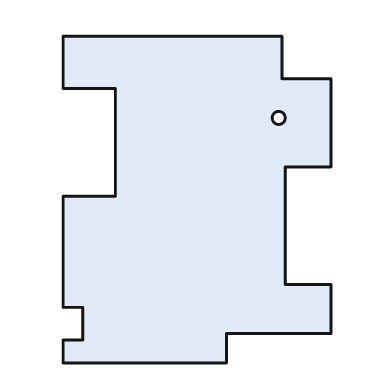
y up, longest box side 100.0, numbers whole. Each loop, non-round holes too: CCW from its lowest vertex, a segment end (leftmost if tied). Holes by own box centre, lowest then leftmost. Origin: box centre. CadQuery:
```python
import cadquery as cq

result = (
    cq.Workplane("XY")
    .moveTo(-41.0, -50.0)
    .lineTo(9.0, -50.0)
    .lineTo(9.0, -41.0)
    .lineTo(41.0, -41.0)
    .lineTo(41.0, -26.0)
    .lineTo(27.0, -26.0)
    .lineTo(27.0, 10.0)
    .lineTo(41.0, 10.0)
    .lineTo(41.0, 37.0)
    .lineTo(26.0, 37.0)
    .lineTo(26.0, 50.0)
    .lineTo(-41.0, 50.0)
    .lineTo(-41.0, 34.0)
    .lineTo(-25.0, 34.0)
    .lineTo(-25.0, 1.0)
    .lineTo(-41.0, 1.0)
    .lineTo(-41.0, -33.0)
    .lineTo(-35.0, -33.0)
    .lineTo(-35.0, -43.0)
    .lineTo(-41.0, -43.0)
    .close()
    .moveTo(25.0, 25.0)
    .circle(2.0)
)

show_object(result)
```